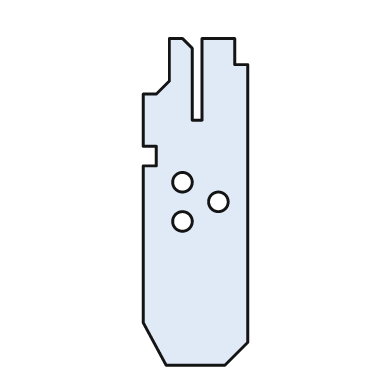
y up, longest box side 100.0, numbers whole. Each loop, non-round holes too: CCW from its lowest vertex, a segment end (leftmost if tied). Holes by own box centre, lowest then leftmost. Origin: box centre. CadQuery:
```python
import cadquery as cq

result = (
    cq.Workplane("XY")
    .moveTo(-9.0, -50.0)
    .lineTo(9.0, -50.0)
    .lineTo(16.0, -43.0)
    .lineTo(16.0, 42.0)
    .lineTo(12.0, 42.0)
    .lineTo(12.0, 50.0)
    .lineTo(2.0, 50.0)
    .lineTo(2.0, 25.0)
    .lineTo(-1.0, 25.0)
    .lineTo(-1.0, 47.0)
    .lineTo(-4.0, 50.0)
    .lineTo(-8.0, 50.0)
    .lineTo(-8.0, 37.0)
    .lineTo(-12.0, 33.0)
    .lineTo(-16.0, 33.0)
    .lineTo(-16.0, 17.0)
    .lineTo(-12.0, 17.0)
    .lineTo(-12.0, 11.0)
    .lineTo(-16.0, 11.0)
    .lineTo(-16.0, -37.0)
    .close()
    .moveTo(-4.0, -6.0)
    .circle(3.0)
    .moveTo(7.0, 0.0)
    .circle(3.0)
    .moveTo(-4.0, 6.0)
    .circle(3.0)
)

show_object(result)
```